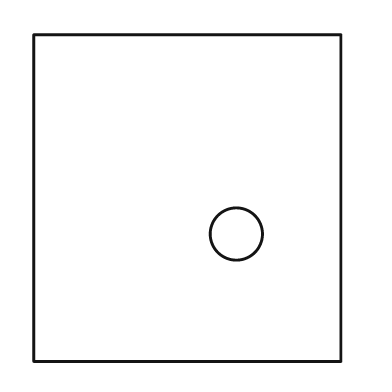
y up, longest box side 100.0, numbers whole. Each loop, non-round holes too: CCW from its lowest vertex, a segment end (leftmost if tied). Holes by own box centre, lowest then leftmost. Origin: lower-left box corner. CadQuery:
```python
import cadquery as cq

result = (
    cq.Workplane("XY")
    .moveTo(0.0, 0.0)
    .lineTo(94.0, 0.0)
    .lineTo(94.0, 100.0)
    .lineTo(0.0, 100.0)
    .close()
    .moveTo(62.0, 39.0)
    .circle(8.0)
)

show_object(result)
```